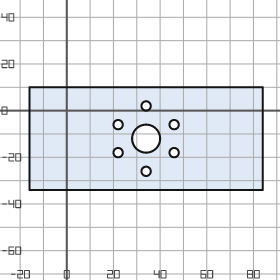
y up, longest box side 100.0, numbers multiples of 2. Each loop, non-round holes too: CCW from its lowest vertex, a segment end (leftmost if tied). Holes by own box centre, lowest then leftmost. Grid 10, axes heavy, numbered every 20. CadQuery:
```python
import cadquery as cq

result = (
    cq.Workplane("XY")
    .moveTo(-16.0, -34.0)
    .lineTo(84.0, -34.0)
    .lineTo(84.0, 10.0)
    .lineTo(-16.0, 10.0)
    .close()
    .moveTo(34.0, -26.0)
    .circle(2.0)
    .moveTo(22.0, -18.0)
    .circle(2.0)
    .moveTo(46.0, -18.0)
    .circle(2.0)
    .moveTo(34.0, -12.0)
    .circle(6.0)
    .moveTo(22.0, -6.0)
    .circle(2.0)
    .moveTo(46.0, -6.0)
    .circle(2.0)
    .moveTo(34.0, 2.0)
    .circle(2.0)
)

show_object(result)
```